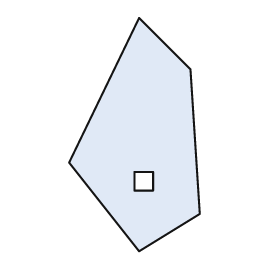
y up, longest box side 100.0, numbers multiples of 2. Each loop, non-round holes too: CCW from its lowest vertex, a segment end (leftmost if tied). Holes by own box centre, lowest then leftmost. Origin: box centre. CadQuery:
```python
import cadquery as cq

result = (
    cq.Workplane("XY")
    .moveTo(2.0, -50.0)
    .lineTo(28.0, -34.0)
    .lineTo(24.0, 28.0)
    .lineTo(2.0, 50.0)
    .lineTo(-28.0, -12.0)
    .close()
    .moveTo(0.0, -24.0)
    .lineTo(8.0, -24.0)
    .lineTo(8.0, -16.0)
    .lineTo(0.0, -16.0)
    .close()
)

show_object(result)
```